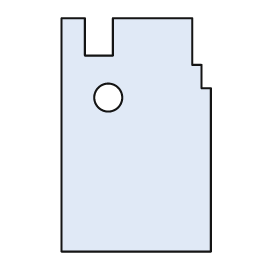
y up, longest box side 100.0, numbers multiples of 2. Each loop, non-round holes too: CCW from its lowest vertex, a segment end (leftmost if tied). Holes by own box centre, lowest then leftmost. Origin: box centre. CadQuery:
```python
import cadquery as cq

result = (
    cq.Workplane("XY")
    .moveTo(-32.0, -50.0)
    .lineTo(32.0, -50.0)
    .lineTo(32.0, 20.0)
    .lineTo(28.0, 20.0)
    .lineTo(28.0, 30.0)
    .lineTo(24.0, 30.0)
    .lineTo(24.0, 50.0)
    .lineTo(-10.0, 50.0)
    .lineTo(-10.0, 34.0)
    .lineTo(-22.0, 34.0)
    .lineTo(-22.0, 50.0)
    .lineTo(-32.0, 50.0)
    .close()
    .moveTo(-12.0, 16.0)
    .circle(6.0)
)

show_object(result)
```